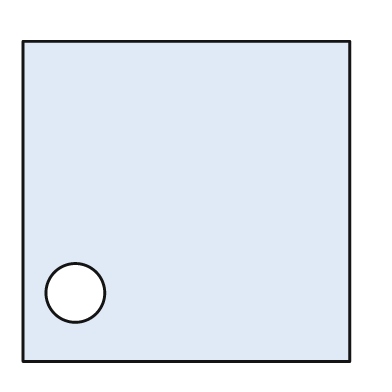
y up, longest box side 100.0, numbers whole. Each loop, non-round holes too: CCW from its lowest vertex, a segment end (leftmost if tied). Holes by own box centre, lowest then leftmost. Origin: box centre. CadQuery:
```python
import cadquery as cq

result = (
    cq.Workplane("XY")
    .moveTo(-50.0, -49.0)
    .lineTo(50.0, -49.0)
    .lineTo(50.0, 49.0)
    .lineTo(-50.0, 49.0)
    .close()
    .moveTo(-34.0, -28.0)
    .circle(9.0)
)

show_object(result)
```